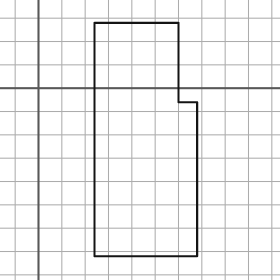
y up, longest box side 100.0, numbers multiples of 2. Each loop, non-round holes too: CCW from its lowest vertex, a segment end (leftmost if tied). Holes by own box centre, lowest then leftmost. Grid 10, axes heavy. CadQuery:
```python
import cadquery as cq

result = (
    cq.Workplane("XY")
    .moveTo(24.0, -72.0)
    .lineTo(68.0, -72.0)
    .lineTo(68.0, -6.0)
    .lineTo(60.0, -6.0)
    .lineTo(60.0, 28.0)
    .lineTo(24.0, 28.0)
    .close()
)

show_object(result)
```